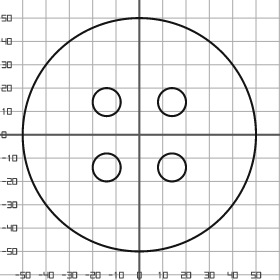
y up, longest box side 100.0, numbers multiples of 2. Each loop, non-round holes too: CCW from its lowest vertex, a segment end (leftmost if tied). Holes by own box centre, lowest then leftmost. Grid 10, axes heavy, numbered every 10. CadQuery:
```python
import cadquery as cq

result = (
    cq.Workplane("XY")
    .moveTo(0.0, 0.0)
    .circle(50.0)
    .moveTo(-14.0, -14.0)
    .circle(6.0)
    .moveTo(14.0, -14.0)
    .circle(6.0)
    .moveTo(-14.0, 14.0)
    .circle(6.0)
    .moveTo(14.0, 14.0)
    .circle(6.0)
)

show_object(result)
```